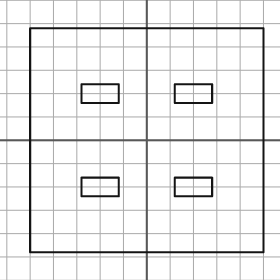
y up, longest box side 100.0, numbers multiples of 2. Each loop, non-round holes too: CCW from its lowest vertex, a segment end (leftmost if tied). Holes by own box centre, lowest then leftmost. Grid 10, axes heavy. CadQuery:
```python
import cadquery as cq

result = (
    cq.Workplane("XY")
    .moveTo(-50.0, -48.0)
    .lineTo(50.0, -48.0)
    .lineTo(50.0, 48.0)
    .lineTo(-50.0, 48.0)
    .close()
    .moveTo(-28.0, -24.0)
    .lineTo(-12.0, -24.0)
    .lineTo(-12.0, -16.0)
    .lineTo(-28.0, -16.0)
    .close()
    .moveTo(12.0, -24.0)
    .lineTo(28.0, -24.0)
    .lineTo(28.0, -16.0)
    .lineTo(12.0, -16.0)
    .close()
    .moveTo(-28.0, 16.0)
    .lineTo(-12.0, 16.0)
    .lineTo(-12.0, 24.0)
    .lineTo(-28.0, 24.0)
    .close()
    .moveTo(12.0, 16.0)
    .lineTo(28.0, 16.0)
    .lineTo(28.0, 24.0)
    .lineTo(12.0, 24.0)
    .close()
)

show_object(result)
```